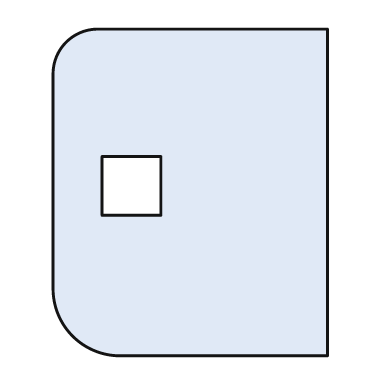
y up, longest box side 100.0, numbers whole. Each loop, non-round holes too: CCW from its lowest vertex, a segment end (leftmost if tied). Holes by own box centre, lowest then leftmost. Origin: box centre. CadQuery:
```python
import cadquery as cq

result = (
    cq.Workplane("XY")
    .moveTo(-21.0, -50.0)
    .lineTo(42.0, -50.0)
    .lineTo(42.0, 50.0)
    .lineTo(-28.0, 50.0)
    .threePointArc((-38.0, 46.0), (-42.0, 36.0))
    .lineTo(-42.0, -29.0)
    .threePointArc((-36.0, -44.0), (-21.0, -50.0))
    .close()
    .moveTo(-27.0, -7.0)
    .lineTo(-9.0, -7.0)
    .lineTo(-9.0, 11.0)
    .lineTo(-27.0, 11.0)
    .close()
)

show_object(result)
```